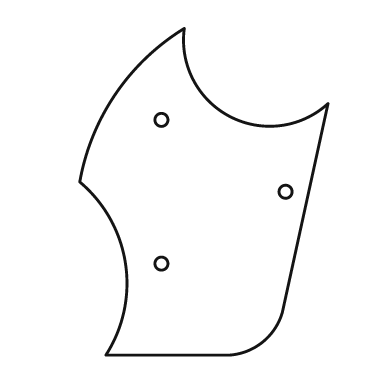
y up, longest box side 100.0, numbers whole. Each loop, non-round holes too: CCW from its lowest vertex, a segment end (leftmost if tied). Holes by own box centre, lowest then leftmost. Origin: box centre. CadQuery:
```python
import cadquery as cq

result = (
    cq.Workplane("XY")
    .moveTo(-30.0, -50.0)
    .lineTo(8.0, -50.0)
    .threePointArc((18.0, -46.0), (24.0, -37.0))
    .lineTo(38.0, 27.0)
    .threePointArc((8.0, 23.0), (-6.0, 50.0))
    .threePointArc((-27.0, 30.0), (-38.0, 3.0))
    .threePointArc((-24.0, -22.0), (-30.0, -50.0))
    .close()
    .moveTo(-13.0, -22.0)
    .circle(2.0)
    .moveTo(25.0, 0.0)
    .circle(2.0)
    .moveTo(-13.0, 22.0)
    .circle(2.0)
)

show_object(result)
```